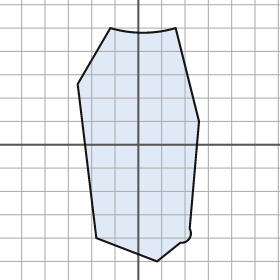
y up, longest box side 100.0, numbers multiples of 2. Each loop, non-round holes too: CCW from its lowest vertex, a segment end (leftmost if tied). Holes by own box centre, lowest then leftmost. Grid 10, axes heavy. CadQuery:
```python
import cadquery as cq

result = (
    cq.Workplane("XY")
    .moveTo(8.0, -50.0)
    .lineTo(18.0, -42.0)
    .threePointArc((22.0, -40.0), (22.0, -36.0))
    .lineTo(26.0, 10.0)
    .lineTo(16.0, 50.0)
    .threePointArc((2.0, 48.0), (-12.0, 50.0))
    .lineTo(-26.0, 26.0)
    .lineTo(-18.0, -40.0)
    .close()
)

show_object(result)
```